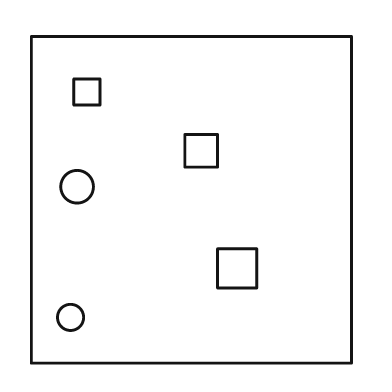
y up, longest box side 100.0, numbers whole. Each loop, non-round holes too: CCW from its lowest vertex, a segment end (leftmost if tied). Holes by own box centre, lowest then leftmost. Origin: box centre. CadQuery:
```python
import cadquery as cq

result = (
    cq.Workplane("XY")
    .moveTo(-49.0, -50.0)
    .lineTo(49.0, -50.0)
    .lineTo(49.0, 50.0)
    .lineTo(-49.0, 50.0)
    .close()
    .moveTo(-37.0, -36.0)
    .circle(4.0)
    .moveTo(8.0, -27.0)
    .lineTo(20.0, -27.0)
    .lineTo(20.0, -15.0)
    .lineTo(8.0, -15.0)
    .close()
    .moveTo(-35.0, 4.0)
    .circle(5.0)
    .moveTo(-2.0, 10.0)
    .lineTo(8.0, 10.0)
    .lineTo(8.0, 20.0)
    .lineTo(-2.0, 20.0)
    .close()
    .moveTo(-36.0, 29.0)
    .lineTo(-28.0, 29.0)
    .lineTo(-28.0, 37.0)
    .lineTo(-36.0, 37.0)
    .close()
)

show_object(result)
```